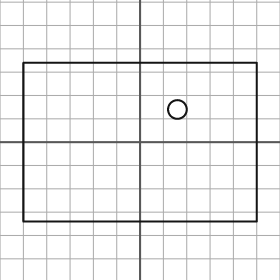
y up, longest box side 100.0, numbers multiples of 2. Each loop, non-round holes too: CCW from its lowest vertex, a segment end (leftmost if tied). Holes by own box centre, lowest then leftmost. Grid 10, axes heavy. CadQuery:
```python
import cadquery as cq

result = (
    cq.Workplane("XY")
    .moveTo(-50.0, -34.0)
    .lineTo(50.0, -34.0)
    .lineTo(50.0, 34.0)
    .lineTo(-50.0, 34.0)
    .close()
    .moveTo(16.0, 14.0)
    .circle(4.0)
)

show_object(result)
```